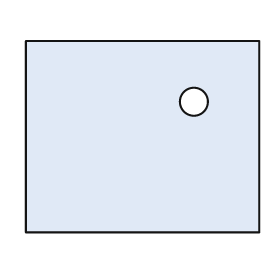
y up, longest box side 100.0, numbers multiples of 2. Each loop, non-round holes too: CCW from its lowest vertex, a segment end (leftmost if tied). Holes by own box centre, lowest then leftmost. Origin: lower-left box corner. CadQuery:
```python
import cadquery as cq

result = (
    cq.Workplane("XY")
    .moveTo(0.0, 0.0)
    .lineTo(100.0, 0.0)
    .lineTo(100.0, 82.0)
    .lineTo(0.0, 82.0)
    .close()
    .moveTo(72.0, 56.0)
    .circle(6.0)
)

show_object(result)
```